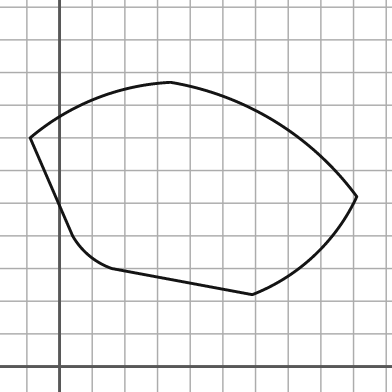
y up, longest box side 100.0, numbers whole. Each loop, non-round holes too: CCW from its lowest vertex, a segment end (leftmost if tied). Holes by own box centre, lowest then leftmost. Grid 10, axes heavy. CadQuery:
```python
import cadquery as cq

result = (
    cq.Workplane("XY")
    .moveTo(59.0, 22.0)
    .threePointArc((78.0, 34.0), (91.0, 52.0))
    .threePointArc((66.0, 75.0), (34.0, 87.0))
    .threePointArc((11.0, 82.0), (-9.0, 70.0))
    .lineTo(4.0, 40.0)
    .threePointArc((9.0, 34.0), (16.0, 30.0))
    .close()
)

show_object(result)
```